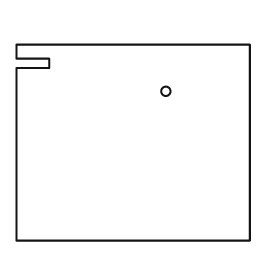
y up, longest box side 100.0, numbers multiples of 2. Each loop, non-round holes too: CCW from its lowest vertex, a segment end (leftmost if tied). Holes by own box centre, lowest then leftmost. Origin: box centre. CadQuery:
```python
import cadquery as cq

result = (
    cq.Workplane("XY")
    .moveTo(-50.0, -42.0)
    .lineTo(50.0, -42.0)
    .lineTo(50.0, 42.0)
    .lineTo(-50.0, 42.0)
    .lineTo(-50.0, 36.0)
    .lineTo(-36.0, 36.0)
    .lineTo(-36.0, 32.0)
    .lineTo(-50.0, 32.0)
    .close()
    .moveTo(14.0, 22.0)
    .circle(2.0)
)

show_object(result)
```